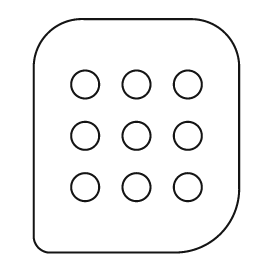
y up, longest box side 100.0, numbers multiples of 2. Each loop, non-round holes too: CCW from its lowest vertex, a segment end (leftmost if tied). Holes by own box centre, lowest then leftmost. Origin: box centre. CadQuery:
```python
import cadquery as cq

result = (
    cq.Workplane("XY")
    .moveTo(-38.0, -50.0)
    .lineTo(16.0, -50.0)
    .threePointArc((36.0, -42.0), (44.0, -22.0))
    .lineTo(44.0, 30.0)
    .threePointArc((38.0, 44.0), (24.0, 50.0))
    .lineTo(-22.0, 50.0)
    .threePointArc((-38.0, 44.0), (-44.0, 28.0))
    .lineTo(-44.0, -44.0)
    .threePointArc((-42.0, -48.0), (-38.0, -50.0))
    .close()
    .moveTo(-22.0, -22.0)
    .circle(6.0)
    .moveTo(0.0, -22.0)
    .circle(6.0)
    .moveTo(22.0, -22.0)
    .circle(6.0)
    .moveTo(-22.0, 0.0)
    .circle(6.0)
    .moveTo(0.0, 0.0)
    .circle(6.0)
    .moveTo(22.0, 0.0)
    .circle(6.0)
    .moveTo(-22.0, 22.0)
    .circle(6.0)
    .moveTo(0.0, 22.0)
    .circle(6.0)
    .moveTo(22.0, 22.0)
    .circle(6.0)
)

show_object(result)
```